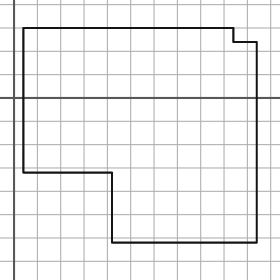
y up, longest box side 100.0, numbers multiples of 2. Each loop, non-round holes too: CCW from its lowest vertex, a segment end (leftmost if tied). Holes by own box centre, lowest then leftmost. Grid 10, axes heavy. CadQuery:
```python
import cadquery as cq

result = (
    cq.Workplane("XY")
    .moveTo(42.0, -62.0)
    .lineTo(104.0, -62.0)
    .lineTo(104.0, 24.0)
    .lineTo(94.0, 24.0)
    .lineTo(94.0, 30.0)
    .lineTo(4.0, 30.0)
    .lineTo(4.0, -32.0)
    .lineTo(42.0, -32.0)
    .close()
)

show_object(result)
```